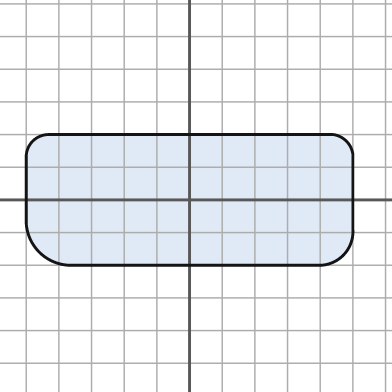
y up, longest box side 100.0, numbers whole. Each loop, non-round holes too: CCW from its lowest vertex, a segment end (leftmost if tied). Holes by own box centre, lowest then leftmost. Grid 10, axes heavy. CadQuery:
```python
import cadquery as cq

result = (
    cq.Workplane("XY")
    .moveTo(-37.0, -20.0)
    .lineTo(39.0, -20.0)
    .threePointArc((47.0, -17.0), (50.0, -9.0))
    .lineTo(50.0, 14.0)
    .threePointArc((48.0, 18.0), (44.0, 20.0))
    .lineTo(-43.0, 20.0)
    .threePointArc((-48.0, 18.0), (-50.0, 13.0))
    .lineTo(-50.0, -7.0)
    .threePointArc((-46.0, -16.0), (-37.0, -20.0))
    .close()
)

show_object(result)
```